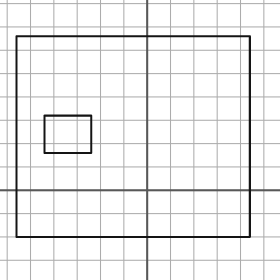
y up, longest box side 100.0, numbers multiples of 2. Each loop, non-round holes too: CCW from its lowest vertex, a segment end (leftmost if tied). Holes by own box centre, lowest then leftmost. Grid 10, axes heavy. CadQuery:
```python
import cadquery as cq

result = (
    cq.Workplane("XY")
    .moveTo(-56.0, -20.0)
    .lineTo(44.0, -20.0)
    .lineTo(44.0, 66.0)
    .lineTo(-56.0, 66.0)
    .close()
    .moveTo(-44.0, 16.0)
    .lineTo(-24.0, 16.0)
    .lineTo(-24.0, 32.0)
    .lineTo(-44.0, 32.0)
    .close()
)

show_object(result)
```